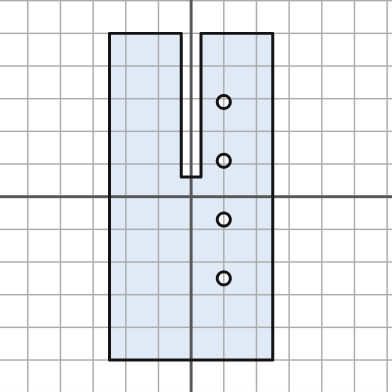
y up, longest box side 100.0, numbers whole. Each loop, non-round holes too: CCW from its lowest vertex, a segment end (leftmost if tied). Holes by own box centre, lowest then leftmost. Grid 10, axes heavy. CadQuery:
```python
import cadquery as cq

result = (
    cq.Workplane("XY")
    .moveTo(-25.0, -50.0)
    .lineTo(25.0, -50.0)
    .lineTo(25.0, 50.0)
    .lineTo(3.0, 50.0)
    .lineTo(3.0, 6.0)
    .lineTo(-3.0, 6.0)
    .lineTo(-3.0, 50.0)
    .lineTo(-25.0, 50.0)
    .close()
    .moveTo(10.0, -25.0)
    .circle(2.0)
    .moveTo(10.0, -7.0)
    .circle(2.0)
    .moveTo(10.0, 11.0)
    .circle(2.0)
    .moveTo(10.0, 29.0)
    .circle(2.0)
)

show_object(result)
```